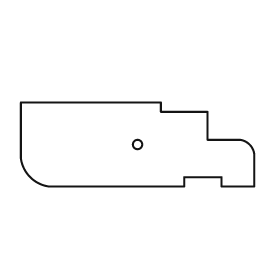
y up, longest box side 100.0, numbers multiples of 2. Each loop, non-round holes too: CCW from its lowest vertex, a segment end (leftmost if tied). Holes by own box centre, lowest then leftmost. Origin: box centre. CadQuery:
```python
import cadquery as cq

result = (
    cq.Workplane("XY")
    .moveTo(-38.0, -18.0)
    .lineTo(20.0, -18.0)
    .lineTo(20.0, -14.0)
    .lineTo(36.0, -14.0)
    .lineTo(36.0, -18.0)
    .lineTo(50.0, -18.0)
    .lineTo(50.0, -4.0)
    .threePointArc((48.0, 0.0), (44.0, 2.0))
    .lineTo(30.0, 2.0)
    .lineTo(30.0, 14.0)
    .lineTo(10.0, 14.0)
    .lineTo(10.0, 18.0)
    .lineTo(-50.0, 18.0)
    .lineTo(-50.0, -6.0)
    .threePointArc((-46.0, -14.0), (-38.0, -18.0))
    .close()
    .moveTo(0.0, 0.0)
    .circle(2.0)
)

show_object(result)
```